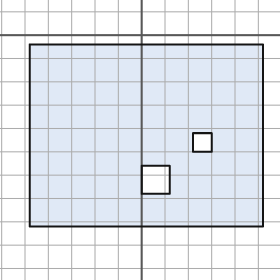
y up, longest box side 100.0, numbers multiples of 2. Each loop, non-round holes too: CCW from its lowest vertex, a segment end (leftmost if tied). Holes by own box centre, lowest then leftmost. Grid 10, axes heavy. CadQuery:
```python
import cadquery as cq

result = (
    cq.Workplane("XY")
    .moveTo(-48.0, -82.0)
    .lineTo(52.0, -82.0)
    .lineTo(52.0, -4.0)
    .lineTo(-48.0, -4.0)
    .close()
    .moveTo(0.0, -68.0)
    .lineTo(12.0, -68.0)
    .lineTo(12.0, -56.0)
    .lineTo(0.0, -56.0)
    .close()
    .moveTo(22.0, -50.0)
    .lineTo(30.0, -50.0)
    .lineTo(30.0, -42.0)
    .lineTo(22.0, -42.0)
    .close()
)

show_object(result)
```